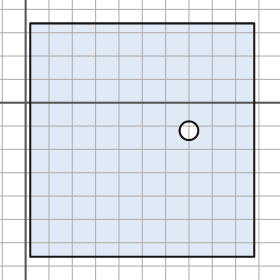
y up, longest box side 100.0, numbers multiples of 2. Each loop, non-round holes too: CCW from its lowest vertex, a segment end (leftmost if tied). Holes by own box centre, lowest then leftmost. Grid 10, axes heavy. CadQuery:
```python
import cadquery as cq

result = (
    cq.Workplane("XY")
    .moveTo(2.0, -66.0)
    .lineTo(98.0, -66.0)
    .lineTo(98.0, 34.0)
    .lineTo(2.0, 34.0)
    .close()
    .moveTo(70.0, -12.0)
    .circle(4.0)
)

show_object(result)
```